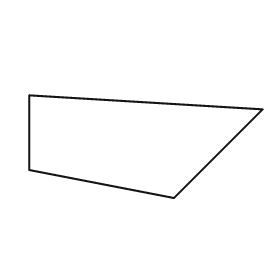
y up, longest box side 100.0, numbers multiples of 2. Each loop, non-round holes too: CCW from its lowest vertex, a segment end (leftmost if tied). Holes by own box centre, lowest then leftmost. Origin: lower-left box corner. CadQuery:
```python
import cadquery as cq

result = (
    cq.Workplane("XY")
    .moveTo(62.0, 0.0)
    .lineTo(100.0, 38.0)
    .lineTo(0.0, 44.0)
    .lineTo(0.0, 12.0)
    .close()
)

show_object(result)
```